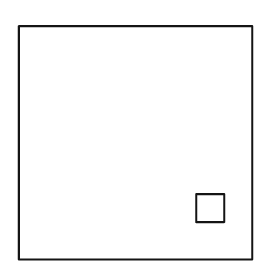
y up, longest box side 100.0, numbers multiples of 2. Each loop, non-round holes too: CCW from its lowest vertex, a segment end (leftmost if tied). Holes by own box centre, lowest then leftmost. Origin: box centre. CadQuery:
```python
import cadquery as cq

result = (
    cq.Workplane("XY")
    .moveTo(-50.0, -50.0)
    .lineTo(50.0, -50.0)
    .lineTo(50.0, 50.0)
    .lineTo(-50.0, 50.0)
    .close()
    .moveTo(26.0, -34.0)
    .lineTo(38.0, -34.0)
    .lineTo(38.0, -22.0)
    .lineTo(26.0, -22.0)
    .close()
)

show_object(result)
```